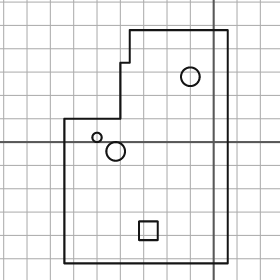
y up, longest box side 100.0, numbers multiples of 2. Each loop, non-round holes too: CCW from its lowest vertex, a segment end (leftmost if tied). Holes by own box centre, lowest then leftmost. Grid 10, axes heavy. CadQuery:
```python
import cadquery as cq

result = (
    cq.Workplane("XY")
    .moveTo(-64.0, -52.0)
    .lineTo(6.0, -52.0)
    .lineTo(6.0, 48.0)
    .lineTo(-36.0, 48.0)
    .lineTo(-36.0, 34.0)
    .lineTo(-40.0, 34.0)
    .lineTo(-40.0, 10.0)
    .lineTo(-64.0, 10.0)
    .close()
    .moveTo(-32.0, -42.0)
    .lineTo(-24.0, -42.0)
    .lineTo(-24.0, -34.0)
    .lineTo(-32.0, -34.0)
    .close()
    .moveTo(-42.0, -4.0)
    .circle(4.0)
    .moveTo(-50.0, 2.0)
    .circle(2.0)
    .moveTo(-10.0, 28.0)
    .circle(4.0)
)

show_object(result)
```